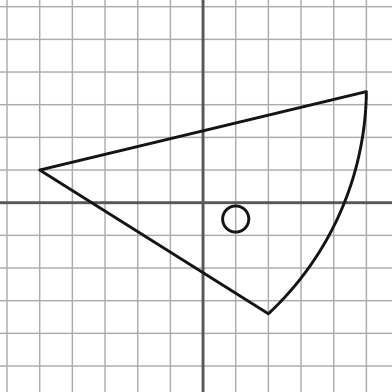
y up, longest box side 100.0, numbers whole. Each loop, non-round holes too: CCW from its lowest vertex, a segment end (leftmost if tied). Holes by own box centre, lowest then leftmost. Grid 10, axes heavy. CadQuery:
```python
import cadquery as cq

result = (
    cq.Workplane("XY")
    .moveTo(20.0, -34.0)
    .threePointArc((42.0, -3.0), (50.0, 34.0))
    .lineTo(-50.0, 10.0)
    .close()
    .moveTo(10.0, -5.0)
    .circle(4.0)
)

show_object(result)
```